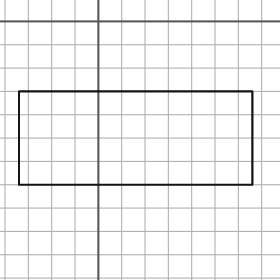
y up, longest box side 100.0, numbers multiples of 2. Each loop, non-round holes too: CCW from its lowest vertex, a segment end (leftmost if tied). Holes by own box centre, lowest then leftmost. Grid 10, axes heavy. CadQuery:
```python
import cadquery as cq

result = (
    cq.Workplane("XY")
    .moveTo(-34.0, -70.0)
    .lineTo(66.0, -70.0)
    .lineTo(66.0, -30.0)
    .lineTo(-34.0, -30.0)
    .close()
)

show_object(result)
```